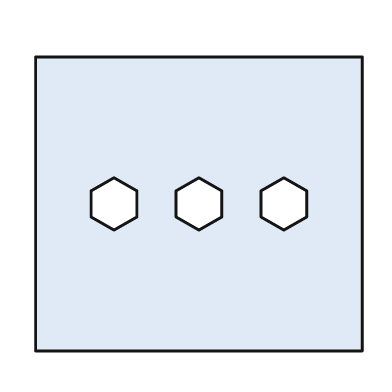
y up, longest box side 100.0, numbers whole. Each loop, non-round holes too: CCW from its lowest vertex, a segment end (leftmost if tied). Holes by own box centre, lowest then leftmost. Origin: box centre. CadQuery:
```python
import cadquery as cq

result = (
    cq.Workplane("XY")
    .moveTo(-50.0, -45.0)
    .lineTo(50.0, -45.0)
    .lineTo(50.0, 45.0)
    .lineTo(-50.0, 45.0)
    .close()
    .moveTo(-26.0, -8.0)
    .lineTo(-19.0, -4.0)
    .lineTo(-19.0, 4.0)
    .lineTo(-26.0, 8.0)
    .lineTo(-33.0, 4.0)
    .lineTo(-33.0, -4.0)
    .close()
    .moveTo(0.0, -8.0)
    .lineTo(7.0, -4.0)
    .lineTo(7.0, 4.0)
    .lineTo(0.0, 8.0)
    .lineTo(-7.0, 4.0)
    .lineTo(-7.0, -4.0)
    .close()
    .moveTo(26.0, -8.0)
    .lineTo(33.0, -4.0)
    .lineTo(33.0, 4.0)
    .lineTo(26.0, 8.0)
    .lineTo(19.0, 4.0)
    .lineTo(19.0, -4.0)
    .close()
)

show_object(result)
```